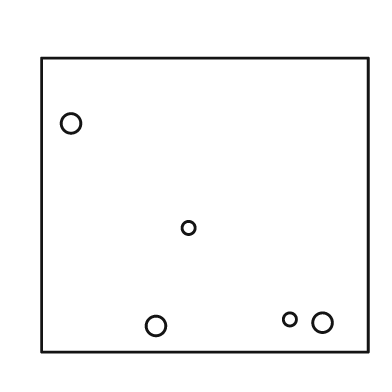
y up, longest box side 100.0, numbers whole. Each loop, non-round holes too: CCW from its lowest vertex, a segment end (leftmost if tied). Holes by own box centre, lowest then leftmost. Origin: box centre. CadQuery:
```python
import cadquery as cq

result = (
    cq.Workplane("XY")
    .moveTo(-50.0, -45.0)
    .lineTo(50.0, -45.0)
    .lineTo(50.0, 45.0)
    .lineTo(-50.0, 45.0)
    .close()
    .moveTo(-15.0, -37.0)
    .circle(3.0)
    .moveTo(36.0, -36.0)
    .circle(3.0)
    .moveTo(26.0, -35.0)
    .circle(2.0)
    .moveTo(-5.0, -7.0)
    .circle(2.0)
    .moveTo(-41.0, 25.0)
    .circle(3.0)
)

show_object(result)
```